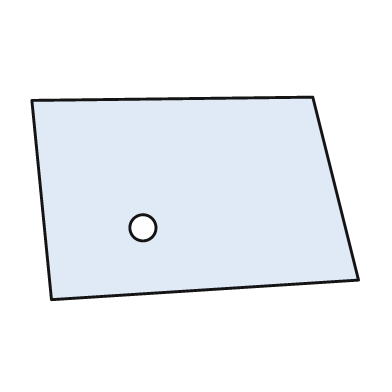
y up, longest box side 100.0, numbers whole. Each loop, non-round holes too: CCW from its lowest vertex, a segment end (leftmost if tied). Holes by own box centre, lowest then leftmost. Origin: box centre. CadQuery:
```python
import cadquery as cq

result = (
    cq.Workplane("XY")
    .moveTo(-44.0, -31.0)
    .lineTo(50.0, -25.0)
    .lineTo(36.0, 31.0)
    .lineTo(-50.0, 30.0)
    .close()
    .moveTo(-16.0, -9.0)
    .circle(4.0)
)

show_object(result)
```